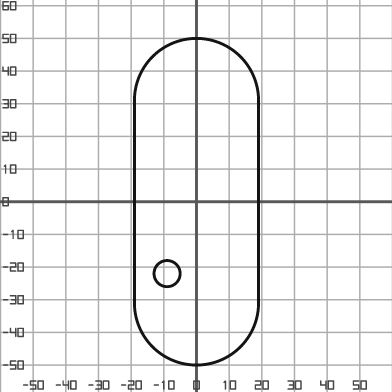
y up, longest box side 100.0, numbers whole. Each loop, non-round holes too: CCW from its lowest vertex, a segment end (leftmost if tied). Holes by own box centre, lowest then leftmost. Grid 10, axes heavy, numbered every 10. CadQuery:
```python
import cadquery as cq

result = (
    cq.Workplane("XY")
    .moveTo(-19.0, -31.0)
    .threePointArc((0.0, -50.0), (19.0, -31.0))
    .lineTo(19.0, 31.0)
    .threePointArc((0.0, 50.0), (-19.0, 31.0))
    .close()
    .moveTo(-9.0, -22.0)
    .circle(4.0)
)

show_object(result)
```